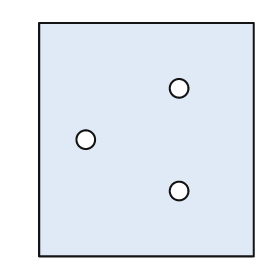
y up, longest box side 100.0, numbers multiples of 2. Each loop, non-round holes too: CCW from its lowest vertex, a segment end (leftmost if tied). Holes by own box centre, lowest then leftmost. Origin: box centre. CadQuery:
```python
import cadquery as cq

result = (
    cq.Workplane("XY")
    .moveTo(-46.0, -50.0)
    .lineTo(46.0, -50.0)
    .lineTo(46.0, 50.0)
    .lineTo(-46.0, 50.0)
    .close()
    .moveTo(14.0, -22.0)
    .circle(4.0)
    .moveTo(-26.0, 0.0)
    .circle(4.0)
    .moveTo(14.0, 22.0)
    .circle(4.0)
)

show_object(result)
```